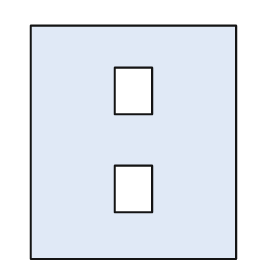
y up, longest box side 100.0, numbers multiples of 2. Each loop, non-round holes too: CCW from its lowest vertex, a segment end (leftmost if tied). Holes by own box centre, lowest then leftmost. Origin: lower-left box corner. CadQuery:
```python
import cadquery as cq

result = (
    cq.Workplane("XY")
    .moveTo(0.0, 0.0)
    .lineTo(88.0, 0.0)
    .lineTo(88.0, 100.0)
    .lineTo(0.0, 100.0)
    .close()
    .moveTo(36.0, 20.0)
    .lineTo(52.0, 20.0)
    .lineTo(52.0, 40.0)
    .lineTo(36.0, 40.0)
    .close()
    .moveTo(36.0, 62.0)
    .lineTo(52.0, 62.0)
    .lineTo(52.0, 82.0)
    .lineTo(36.0, 82.0)
    .close()
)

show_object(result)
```